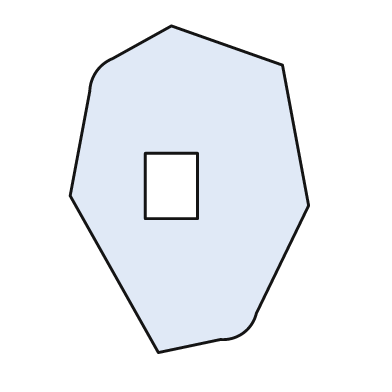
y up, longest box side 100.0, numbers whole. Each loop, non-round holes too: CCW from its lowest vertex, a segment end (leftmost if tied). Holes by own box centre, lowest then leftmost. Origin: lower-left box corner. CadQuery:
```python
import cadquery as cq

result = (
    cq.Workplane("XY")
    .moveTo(27.0, 0.0)
    .lineTo(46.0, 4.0)
    .threePointArc((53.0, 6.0), (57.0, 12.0))
    .lineTo(73.0, 45.0)
    .lineTo(65.0, 88.0)
    .lineTo(31.0, 100.0)
    .lineTo(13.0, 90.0)
    .threePointArc((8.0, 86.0), (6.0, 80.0))
    .lineTo(0.0, 48.0)
    .close()
    .moveTo(23.0, 41.0)
    .lineTo(39.0, 41.0)
    .lineTo(39.0, 61.0)
    .lineTo(23.0, 61.0)
    .close()
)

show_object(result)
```